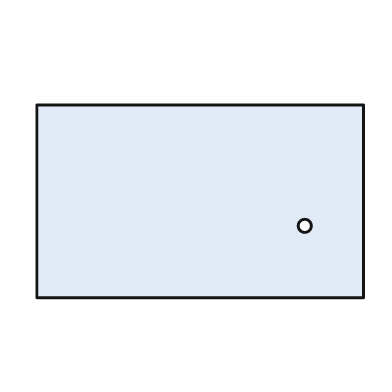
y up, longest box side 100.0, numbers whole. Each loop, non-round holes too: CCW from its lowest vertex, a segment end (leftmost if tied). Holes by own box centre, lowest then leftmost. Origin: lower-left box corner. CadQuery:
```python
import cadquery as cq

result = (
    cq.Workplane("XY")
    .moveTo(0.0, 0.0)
    .lineTo(100.0, 0.0)
    .lineTo(100.0, 59.0)
    .lineTo(0.0, 59.0)
    .close()
    .moveTo(82.0, 22.0)
    .circle(2.0)
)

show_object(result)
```